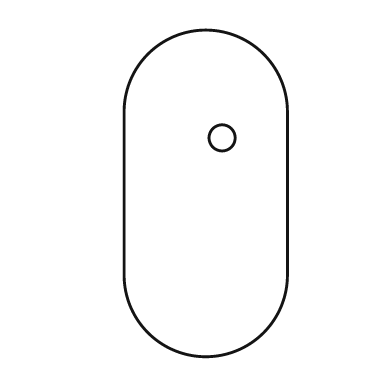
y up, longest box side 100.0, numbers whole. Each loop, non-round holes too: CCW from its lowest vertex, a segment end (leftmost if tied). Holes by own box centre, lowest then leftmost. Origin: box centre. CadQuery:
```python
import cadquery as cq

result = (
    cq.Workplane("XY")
    .moveTo(-25.0, -25.0)
    .threePointArc((0.0, -50.0), (25.0, -25.0))
    .lineTo(25.0, 25.0)
    .threePointArc((0.0, 50.0), (-25.0, 25.0))
    .close()
    .moveTo(5.0, 17.0)
    .circle(4.0)
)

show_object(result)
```